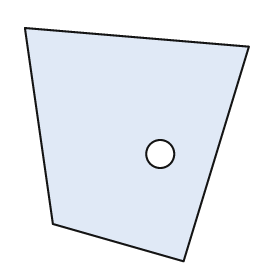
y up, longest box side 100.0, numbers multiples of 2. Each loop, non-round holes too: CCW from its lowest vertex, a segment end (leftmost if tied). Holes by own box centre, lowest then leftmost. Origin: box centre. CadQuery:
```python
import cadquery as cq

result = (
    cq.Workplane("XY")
    .moveTo(20.0, -50.0)
    .lineTo(48.0, 42.0)
    .lineTo(-48.0, 50.0)
    .lineTo(-36.0, -34.0)
    .close()
    .moveTo(10.0, -4.0)
    .circle(6.0)
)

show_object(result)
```